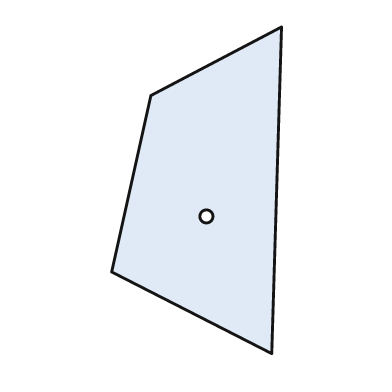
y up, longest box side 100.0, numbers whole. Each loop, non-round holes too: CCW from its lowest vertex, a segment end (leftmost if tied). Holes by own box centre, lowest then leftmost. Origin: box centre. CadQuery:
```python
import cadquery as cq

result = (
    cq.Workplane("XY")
    .moveTo(23.0, -50.0)
    .lineTo(26.0, 50.0)
    .lineTo(-14.0, 29.0)
    .lineTo(-26.0, -25.0)
    .close()
    .moveTo(3.0, -8.0)
    .circle(2.0)
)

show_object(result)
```